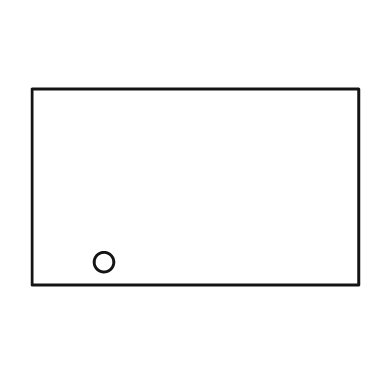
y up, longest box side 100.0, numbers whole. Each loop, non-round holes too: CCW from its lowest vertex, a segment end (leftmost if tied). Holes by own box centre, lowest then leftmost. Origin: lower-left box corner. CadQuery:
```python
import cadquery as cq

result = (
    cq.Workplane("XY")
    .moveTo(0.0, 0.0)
    .lineTo(100.0, 0.0)
    .lineTo(100.0, 60.0)
    .lineTo(0.0, 60.0)
    .close()
    .moveTo(22.0, 7.0)
    .circle(3.0)
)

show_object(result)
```